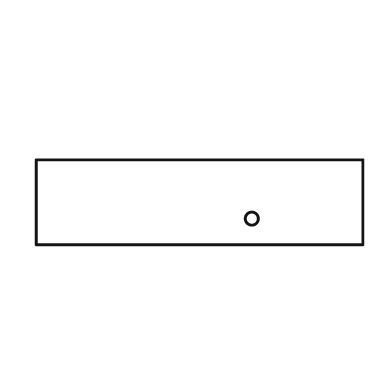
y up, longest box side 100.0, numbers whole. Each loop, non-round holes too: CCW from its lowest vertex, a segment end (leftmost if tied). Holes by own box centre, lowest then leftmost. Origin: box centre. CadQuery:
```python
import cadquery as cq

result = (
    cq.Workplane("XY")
    .moveTo(-50.0, -13.0)
    .lineTo(50.0, -13.0)
    .lineTo(50.0, 13.0)
    .lineTo(-50.0, 13.0)
    .close()
    .moveTo(16.0, -5.0)
    .circle(2.0)
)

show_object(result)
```